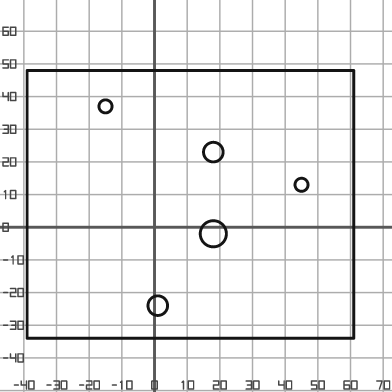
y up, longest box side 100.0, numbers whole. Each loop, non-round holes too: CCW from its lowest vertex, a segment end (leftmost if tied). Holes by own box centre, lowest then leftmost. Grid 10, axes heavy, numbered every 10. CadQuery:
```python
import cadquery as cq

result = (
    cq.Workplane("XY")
    .moveTo(-39.0, -34.0)
    .lineTo(61.0, -34.0)
    .lineTo(61.0, 48.0)
    .lineTo(-39.0, 48.0)
    .close()
    .moveTo(1.0, -24.0)
    .circle(3.0)
    .moveTo(18.0, -2.0)
    .circle(4.0)
    .moveTo(45.0, 13.0)
    .circle(2.0)
    .moveTo(18.0, 23.0)
    .circle(3.0)
    .moveTo(-15.0, 37.0)
    .circle(2.0)
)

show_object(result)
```